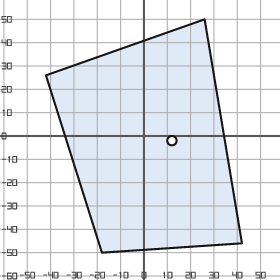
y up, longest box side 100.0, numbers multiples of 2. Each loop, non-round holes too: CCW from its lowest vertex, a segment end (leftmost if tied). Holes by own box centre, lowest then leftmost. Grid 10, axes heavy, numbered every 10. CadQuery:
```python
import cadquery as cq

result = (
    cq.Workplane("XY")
    .moveTo(-18.0, -50.0)
    .lineTo(42.0, -46.0)
    .lineTo(26.0, 50.0)
    .lineTo(-42.0, 26.0)
    .close()
    .moveTo(12.0, -2.0)
    .circle(2.0)
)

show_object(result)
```